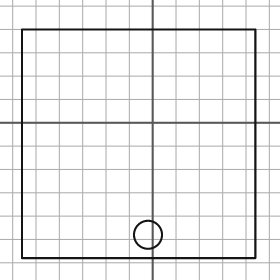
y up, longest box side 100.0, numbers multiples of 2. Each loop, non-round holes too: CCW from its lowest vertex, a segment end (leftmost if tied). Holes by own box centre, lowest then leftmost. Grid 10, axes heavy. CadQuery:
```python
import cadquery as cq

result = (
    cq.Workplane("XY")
    .moveTo(-56.0, -58.0)
    .lineTo(44.0, -58.0)
    .lineTo(44.0, 40.0)
    .lineTo(-56.0, 40.0)
    .close()
    .moveTo(-2.0, -48.0)
    .circle(6.0)
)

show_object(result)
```